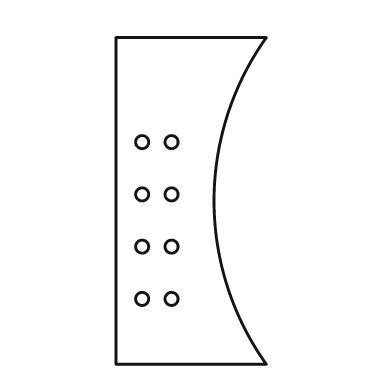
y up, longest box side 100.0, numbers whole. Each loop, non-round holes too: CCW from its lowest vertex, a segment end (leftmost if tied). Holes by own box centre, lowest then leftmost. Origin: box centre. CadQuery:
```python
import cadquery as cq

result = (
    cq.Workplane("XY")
    .moveTo(-23.0, -50.0)
    .lineTo(23.0, -50.0)
    .threePointArc((7.0, 0.0), (23.0, 50.0))
    .lineTo(-23.0, 50.0)
    .close()
    .moveTo(-15.0, -30.0)
    .circle(2.0)
    .moveTo(-6.0, -30.0)
    .circle(2.0)
    .moveTo(-15.0, -14.0)
    .circle(2.0)
    .moveTo(-6.0, -14.0)
    .circle(2.0)
    .moveTo(-15.0, 2.0)
    .circle(2.0)
    .moveTo(-6.0, 2.0)
    .circle(2.0)
    .moveTo(-15.0, 18.0)
    .circle(2.0)
    .moveTo(-6.0, 18.0)
    .circle(2.0)
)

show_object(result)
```